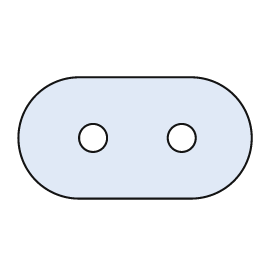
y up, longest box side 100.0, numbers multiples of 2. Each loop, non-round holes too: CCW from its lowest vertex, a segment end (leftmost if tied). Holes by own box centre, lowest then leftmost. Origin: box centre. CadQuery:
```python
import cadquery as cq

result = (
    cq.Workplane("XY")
    .moveTo(-24.0, -26.0)
    .lineTo(24.0, -26.0)
    .threePointArc((50.0, 0.0), (24.0, 26.0))
    .lineTo(-24.0, 26.0)
    .threePointArc((-50.0, 0.0), (-24.0, -26.0))
    .close()
    .moveTo(-18.0, 0.0)
    .circle(6.0)
    .moveTo(20.0, 0.0)
    .circle(6.0)
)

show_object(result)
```